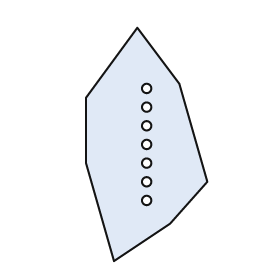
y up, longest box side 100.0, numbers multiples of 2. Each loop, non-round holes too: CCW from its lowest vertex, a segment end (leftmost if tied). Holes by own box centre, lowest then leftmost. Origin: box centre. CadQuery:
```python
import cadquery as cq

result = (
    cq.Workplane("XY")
    .moveTo(-14.0, -50.0)
    .lineTo(10.0, -34.0)
    .lineTo(26.0, -16.0)
    .lineTo(14.0, 26.0)
    .lineTo(-4.0, 50.0)
    .lineTo(-26.0, 20.0)
    .lineTo(-26.0, -8.0)
    .close()
    .moveTo(0.0, -24.0)
    .circle(2.0)
    .moveTo(0.0, -16.0)
    .circle(2.0)
    .moveTo(0.0, -8.0)
    .circle(2.0)
    .moveTo(0.0, 0.0)
    .circle(2.0)
    .moveTo(0.0, 8.0)
    .circle(2.0)
    .moveTo(0.0, 16.0)
    .circle(2.0)
    .moveTo(0.0, 24.0)
    .circle(2.0)
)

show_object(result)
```